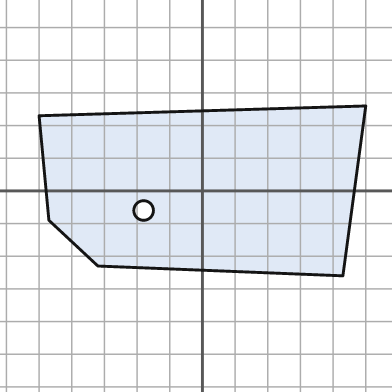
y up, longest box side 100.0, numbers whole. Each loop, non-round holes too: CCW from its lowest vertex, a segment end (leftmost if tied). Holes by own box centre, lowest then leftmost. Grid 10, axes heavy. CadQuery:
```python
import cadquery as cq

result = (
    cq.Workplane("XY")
    .moveTo(43.0, -26.0)
    .lineTo(50.0, 26.0)
    .lineTo(-50.0, 23.0)
    .lineTo(-47.0, -9.0)
    .lineTo(-32.0, -23.0)
    .close()
    .moveTo(-18.0, -6.0)
    .circle(3.0)
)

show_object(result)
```